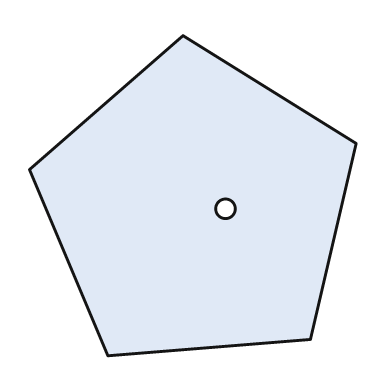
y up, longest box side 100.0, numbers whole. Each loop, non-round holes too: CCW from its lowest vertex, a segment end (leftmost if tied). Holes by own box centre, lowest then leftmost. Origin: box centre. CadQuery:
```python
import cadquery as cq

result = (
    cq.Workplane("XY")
    .moveTo(-26.0, -49.0)
    .lineTo(36.0, -44.0)
    .lineTo(50.0, 16.0)
    .lineTo(-3.0, 49.0)
    .lineTo(-50.0, 8.0)
    .close()
    .moveTo(10.0, -4.0)
    .circle(3.0)
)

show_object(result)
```